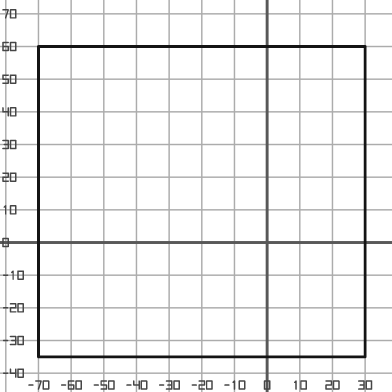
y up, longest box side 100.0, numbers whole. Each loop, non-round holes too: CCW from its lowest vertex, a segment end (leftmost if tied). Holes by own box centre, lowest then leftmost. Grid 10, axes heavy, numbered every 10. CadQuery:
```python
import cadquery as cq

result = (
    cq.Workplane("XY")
    .moveTo(-70.0, -35.0)
    .lineTo(30.0, -35.0)
    .lineTo(30.0, 60.0)
    .lineTo(-70.0, 60.0)
    .close()
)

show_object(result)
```